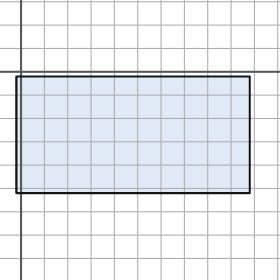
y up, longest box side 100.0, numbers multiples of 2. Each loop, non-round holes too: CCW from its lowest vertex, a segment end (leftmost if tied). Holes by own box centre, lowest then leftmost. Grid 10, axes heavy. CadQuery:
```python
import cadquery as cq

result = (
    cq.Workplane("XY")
    .moveTo(-2.0, -52.0)
    .lineTo(98.0, -52.0)
    .lineTo(98.0, -2.0)
    .lineTo(-2.0, -2.0)
    .close()
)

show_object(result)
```